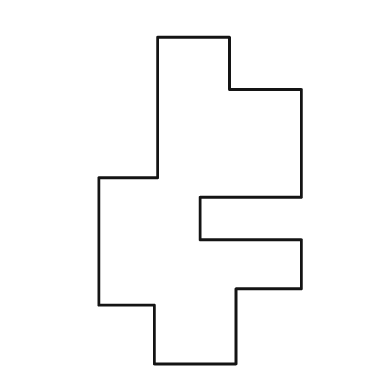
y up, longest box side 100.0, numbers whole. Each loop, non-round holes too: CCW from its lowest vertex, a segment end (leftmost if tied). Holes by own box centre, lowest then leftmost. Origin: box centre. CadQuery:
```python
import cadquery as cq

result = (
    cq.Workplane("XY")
    .moveTo(-14.0, -50.0)
    .lineTo(11.0, -50.0)
    .lineTo(11.0, -27.0)
    .lineTo(31.0, -27.0)
    .lineTo(31.0, -12.0)
    .lineTo(0.0, -12.0)
    .lineTo(0.0, 1.0)
    .lineTo(31.0, 1.0)
    .lineTo(31.0, 34.0)
    .lineTo(9.0, 34.0)
    .lineTo(9.0, 50.0)
    .lineTo(-13.0, 50.0)
    .lineTo(-13.0, 7.0)
    .lineTo(-31.0, 7.0)
    .lineTo(-31.0, -32.0)
    .lineTo(-14.0, -32.0)
    .close()
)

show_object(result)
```